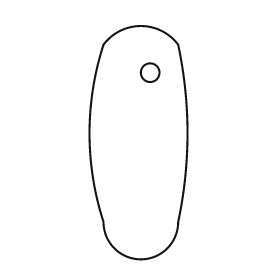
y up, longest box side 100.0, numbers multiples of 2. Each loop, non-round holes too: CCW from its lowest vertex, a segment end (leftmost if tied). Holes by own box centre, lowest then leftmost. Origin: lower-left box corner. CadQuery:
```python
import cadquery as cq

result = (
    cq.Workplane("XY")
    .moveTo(6.0, 16.0)
    .threePointArc((22.0, 0.0), (38.0, 16.0))
    .threePointArc((42.0, 54.0), (38.0, 92.0))
    .threePointArc((22.0, 100.0), (6.0, 92.0))
    .threePointArc((0.0, 54.0), (6.0, 16.0))
    .close()
    .moveTo(26.0, 80.0)
    .circle(4.0)
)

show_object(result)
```